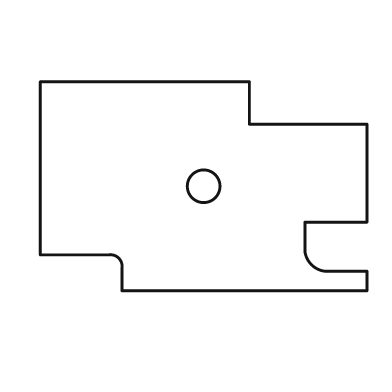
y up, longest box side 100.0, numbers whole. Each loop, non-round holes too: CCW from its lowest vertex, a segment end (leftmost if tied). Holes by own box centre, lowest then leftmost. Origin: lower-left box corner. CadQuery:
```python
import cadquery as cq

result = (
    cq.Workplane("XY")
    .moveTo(25.0, 0.0)
    .lineTo(100.0, 0.0)
    .lineTo(100.0, 6.0)
    .lineTo(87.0, 6.0)
    .threePointArc((83.0, 8.0), (81.0, 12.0))
    .lineTo(81.0, 21.0)
    .lineTo(100.0, 21.0)
    .lineTo(100.0, 51.0)
    .lineTo(64.0, 51.0)
    .lineTo(64.0, 64.0)
    .lineTo(0.0, 64.0)
    .lineTo(0.0, 11.0)
    .lineTo(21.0, 11.0)
    .threePointArc((24.0, 10.0), (25.0, 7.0))
    .close()
    .moveTo(50.0, 32.0)
    .circle(5.0)
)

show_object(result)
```